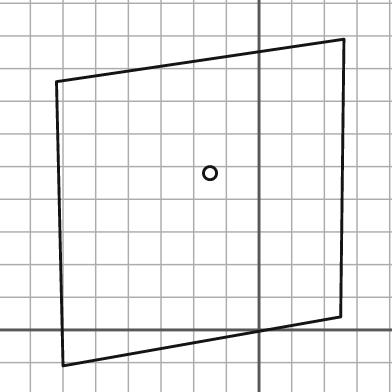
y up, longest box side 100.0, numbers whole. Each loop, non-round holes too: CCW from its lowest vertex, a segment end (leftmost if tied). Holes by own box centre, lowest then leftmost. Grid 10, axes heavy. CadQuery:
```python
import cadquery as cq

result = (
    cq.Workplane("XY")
    .moveTo(-60.0, -11.0)
    .lineTo(25.0, 4.0)
    .lineTo(26.0, 89.0)
    .lineTo(-62.0, 76.0)
    .close()
    .moveTo(-15.0, 48.0)
    .circle(2.0)
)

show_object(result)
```